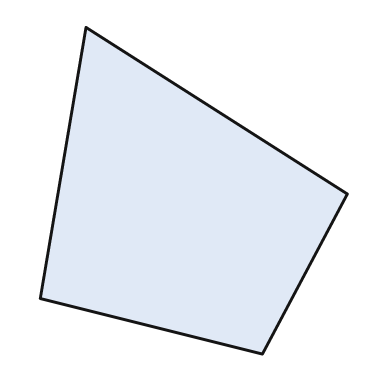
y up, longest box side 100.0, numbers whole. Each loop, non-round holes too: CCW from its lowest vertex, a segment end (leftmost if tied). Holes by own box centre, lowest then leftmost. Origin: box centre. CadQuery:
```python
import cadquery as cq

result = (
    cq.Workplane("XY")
    .moveTo(21.0, -50.0)
    .lineTo(47.0, -1.0)
    .lineTo(-33.0, 50.0)
    .lineTo(-47.0, -33.0)
    .close()
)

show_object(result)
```